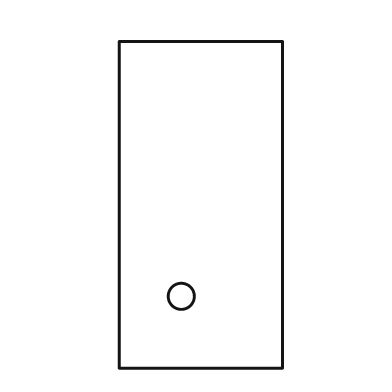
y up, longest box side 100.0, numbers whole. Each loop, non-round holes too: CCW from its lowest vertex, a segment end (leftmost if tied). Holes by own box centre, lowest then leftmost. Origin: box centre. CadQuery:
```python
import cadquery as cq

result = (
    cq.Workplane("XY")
    .moveTo(-25.0, -50.0)
    .lineTo(25.0, -50.0)
    .lineTo(25.0, 50.0)
    .lineTo(-25.0, 50.0)
    .close()
    .moveTo(-6.0, -28.0)
    .circle(4.0)
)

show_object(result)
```